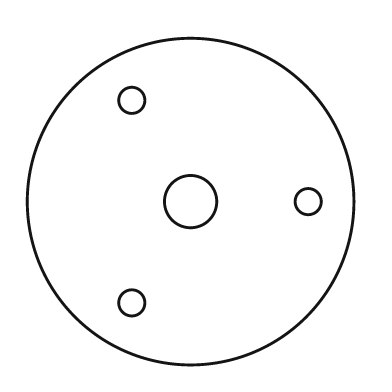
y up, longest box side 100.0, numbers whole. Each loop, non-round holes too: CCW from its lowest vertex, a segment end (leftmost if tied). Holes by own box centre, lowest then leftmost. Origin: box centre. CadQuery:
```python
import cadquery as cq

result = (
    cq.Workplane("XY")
    .moveTo(0.0, 0.0)
    .circle(50.0)
    .moveTo(-18.0, -31.0)
    .circle(4.0)
    .moveTo(0.0, 0.0)
    .circle(8.0)
    .moveTo(36.0, 0.0)
    .circle(4.0)
    .moveTo(-18.0, 31.0)
    .circle(4.0)
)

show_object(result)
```